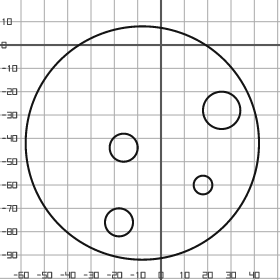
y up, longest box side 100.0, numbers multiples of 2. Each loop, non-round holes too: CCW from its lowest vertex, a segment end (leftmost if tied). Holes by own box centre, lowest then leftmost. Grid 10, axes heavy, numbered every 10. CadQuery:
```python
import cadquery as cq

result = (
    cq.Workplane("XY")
    .moveTo(-8.0, -42.0)
    .circle(50.0)
    .moveTo(-18.0, -76.0)
    .circle(6.0)
    .moveTo(18.0, -60.0)
    .circle(4.0)
    .moveTo(-16.0, -44.0)
    .circle(6.0)
    .moveTo(26.0, -28.0)
    .circle(8.0)
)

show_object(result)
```